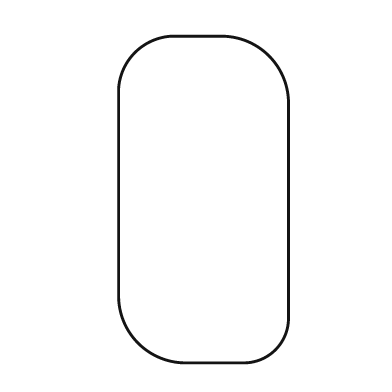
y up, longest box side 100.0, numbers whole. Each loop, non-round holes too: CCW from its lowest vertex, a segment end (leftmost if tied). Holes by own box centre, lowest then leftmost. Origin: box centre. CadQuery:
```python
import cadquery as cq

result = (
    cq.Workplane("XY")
    .moveTo(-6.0, -50.0)
    .lineTo(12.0, -50.0)
    .threePointArc((22.0, -46.0), (26.0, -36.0))
    .lineTo(26.0, 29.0)
    .threePointArc((20.0, 44.0), (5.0, 50.0))
    .lineTo(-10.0, 50.0)
    .threePointArc((-21.0, 45.0), (-26.0, 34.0))
    .lineTo(-26.0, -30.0)
    .threePointArc((-20.0, -44.0), (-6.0, -50.0))
    .close()
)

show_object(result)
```